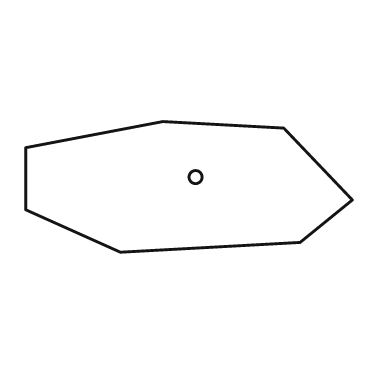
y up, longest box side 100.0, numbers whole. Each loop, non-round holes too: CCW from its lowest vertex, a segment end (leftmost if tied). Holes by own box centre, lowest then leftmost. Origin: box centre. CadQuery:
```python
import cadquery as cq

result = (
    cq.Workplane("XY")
    .moveTo(-21.0, -20.0)
    .lineTo(34.0, -17.0)
    .lineTo(50.0, -4.0)
    .lineTo(29.0, 18.0)
    .lineTo(-8.0, 20.0)
    .lineTo(-50.0, 12.0)
    .lineTo(-50.0, -7.0)
    .close()
    .moveTo(2.0, 3.0)
    .circle(2.0)
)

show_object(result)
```